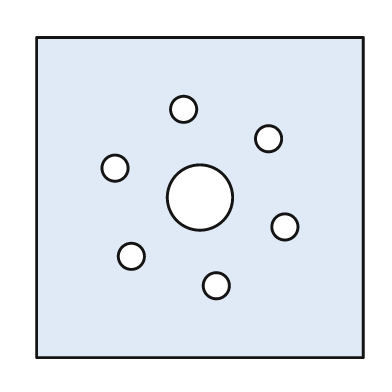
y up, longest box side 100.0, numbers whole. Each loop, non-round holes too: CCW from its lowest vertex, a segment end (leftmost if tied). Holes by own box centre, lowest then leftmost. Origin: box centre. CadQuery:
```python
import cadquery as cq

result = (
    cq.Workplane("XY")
    .moveTo(-50.0, -49.0)
    .lineTo(50.0, -49.0)
    .lineTo(50.0, 49.0)
    .lineTo(-50.0, 49.0)
    .close()
    .moveTo(5.0, -27.0)
    .circle(4.0)
    .moveTo(-21.0, -18.0)
    .circle(4.0)
    .moveTo(26.0, -9.0)
    .circle(4.0)
    .moveTo(0.0, 0.0)
    .circle(10.0)
    .moveTo(-26.0, 9.0)
    .circle(4.0)
    .moveTo(21.0, 18.0)
    .circle(4.0)
    .moveTo(-5.0, 27.0)
    .circle(4.0)
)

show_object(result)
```